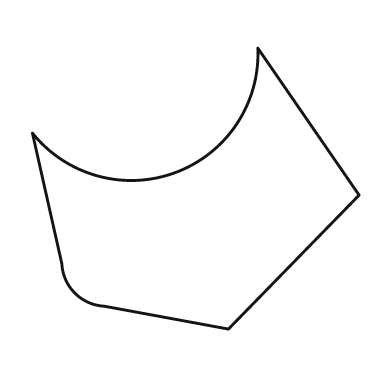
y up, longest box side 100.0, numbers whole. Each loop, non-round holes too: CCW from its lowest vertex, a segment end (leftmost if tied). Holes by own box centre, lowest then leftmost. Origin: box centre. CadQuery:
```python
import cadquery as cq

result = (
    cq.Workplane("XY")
    .moveTo(10.0, -43.0)
    .lineTo(50.0, -2.0)
    .lineTo(19.0, 43.0)
    .threePointArc((-6.0, 5.0), (-50.0, 17.0))
    .lineTo(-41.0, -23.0)
    .threePointArc((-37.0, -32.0), (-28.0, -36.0))
    .close()
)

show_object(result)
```